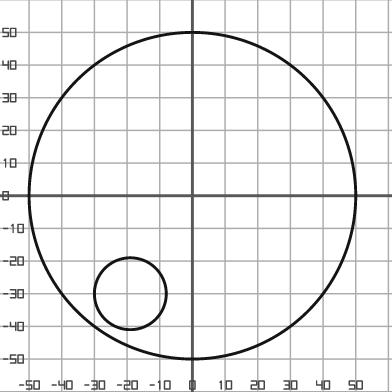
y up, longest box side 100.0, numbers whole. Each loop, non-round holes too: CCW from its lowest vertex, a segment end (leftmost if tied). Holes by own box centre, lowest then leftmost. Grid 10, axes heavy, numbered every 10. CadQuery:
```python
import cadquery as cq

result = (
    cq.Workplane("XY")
    .moveTo(0.0, 0.0)
    .circle(50.0)
    .moveTo(-19.0, -30.0)
    .circle(11.0)
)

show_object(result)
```